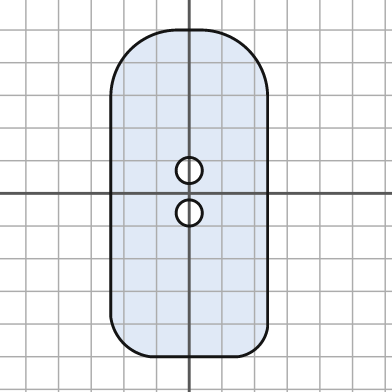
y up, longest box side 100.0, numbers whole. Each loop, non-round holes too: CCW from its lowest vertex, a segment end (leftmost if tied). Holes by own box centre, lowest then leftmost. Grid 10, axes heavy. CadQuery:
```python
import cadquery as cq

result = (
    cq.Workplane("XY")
    .moveTo(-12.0, -50.0)
    .lineTo(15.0, -50.0)
    .threePointArc((21.0, -47.0), (24.0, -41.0))
    .lineTo(24.0, 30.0)
    .threePointArc((18.0, 44.0), (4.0, 50.0))
    .lineTo(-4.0, 50.0)
    .threePointArc((-18.0, 44.0), (-24.0, 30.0))
    .lineTo(-24.0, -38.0)
    .threePointArc((-20.0, -46.0), (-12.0, -50.0))
    .close()
    .moveTo(0.0, -6.0)
    .circle(4.0)
    .moveTo(0.0, 7.0)
    .circle(4.0)
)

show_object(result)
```